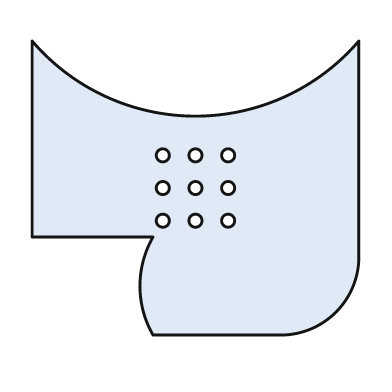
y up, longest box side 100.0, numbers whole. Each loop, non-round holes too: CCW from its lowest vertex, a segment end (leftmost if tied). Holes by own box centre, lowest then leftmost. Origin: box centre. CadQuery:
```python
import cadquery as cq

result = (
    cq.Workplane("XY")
    .moveTo(-13.0, -45.0)
    .lineTo(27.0, -45.0)
    .threePointArc((43.0, -38.0), (50.0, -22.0))
    .lineTo(50.0, 45.0)
    .threePointArc((0.0, 22.0), (-50.0, 45.0))
    .lineTo(-50.0, -15.0)
    .lineTo(-13.0, -15.0)
    .threePointArc((-17.0, -30.0), (-13.0, -45.0))
    .close()
    .moveTo(-10.0, -10.0)
    .circle(2.0)
    .moveTo(0.0, -10.0)
    .circle(2.0)
    .moveTo(10.0, -10.0)
    .circle(2.0)
    .moveTo(-10.0, 0.0)
    .circle(2.0)
    .moveTo(0.0, 0.0)
    .circle(2.0)
    .moveTo(10.0, 0.0)
    .circle(2.0)
    .moveTo(-10.0, 10.0)
    .circle(2.0)
    .moveTo(0.0, 10.0)
    .circle(2.0)
    .moveTo(10.0, 10.0)
    .circle(2.0)
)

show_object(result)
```